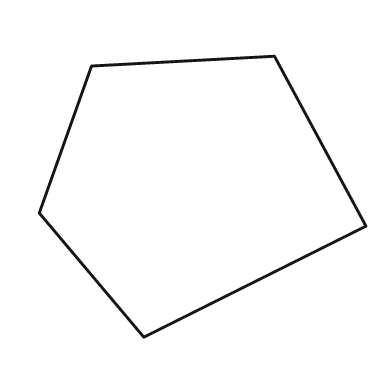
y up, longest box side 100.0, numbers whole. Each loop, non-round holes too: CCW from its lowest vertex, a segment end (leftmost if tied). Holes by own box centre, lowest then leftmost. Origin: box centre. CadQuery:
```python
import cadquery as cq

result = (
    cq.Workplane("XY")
    .moveTo(-18.0, -43.0)
    .lineTo(50.0, -9.0)
    .lineTo(22.0, 43.0)
    .lineTo(-34.0, 40.0)
    .lineTo(-50.0, -5.0)
    .close()
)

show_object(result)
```